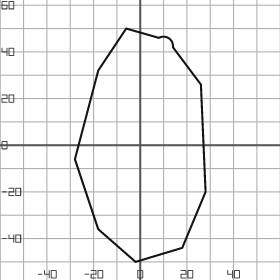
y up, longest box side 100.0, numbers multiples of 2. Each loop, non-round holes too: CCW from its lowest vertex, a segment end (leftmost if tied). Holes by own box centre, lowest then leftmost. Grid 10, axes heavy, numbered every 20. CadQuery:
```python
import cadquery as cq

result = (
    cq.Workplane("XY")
    .moveTo(-2.0, -50.0)
    .lineTo(18.0, -44.0)
    .lineTo(28.0, -20.0)
    .lineTo(26.0, 26.0)
    .lineTo(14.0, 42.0)
    .threePointArc((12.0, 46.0), (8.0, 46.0))
    .lineTo(-6.0, 50.0)
    .lineTo(-18.0, 32.0)
    .lineTo(-28.0, -6.0)
    .lineTo(-18.0, -36.0)
    .close()
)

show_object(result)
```